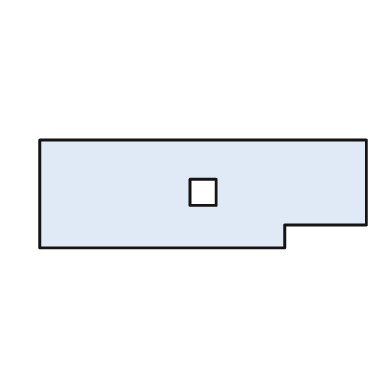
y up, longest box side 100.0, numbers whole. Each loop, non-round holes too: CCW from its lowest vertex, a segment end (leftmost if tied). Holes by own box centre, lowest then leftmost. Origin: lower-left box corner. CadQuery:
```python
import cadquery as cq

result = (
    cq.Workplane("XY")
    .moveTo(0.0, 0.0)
    .lineTo(75.0, 0.0)
    .lineTo(75.0, 7.0)
    .lineTo(100.0, 7.0)
    .lineTo(100.0, 33.0)
    .lineTo(0.0, 33.0)
    .close()
    .moveTo(46.0, 13.0)
    .lineTo(54.0, 13.0)
    .lineTo(54.0, 21.0)
    .lineTo(46.0, 21.0)
    .close()
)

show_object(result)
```